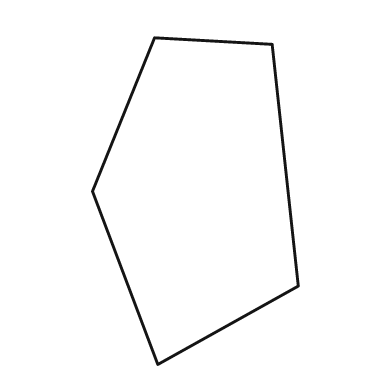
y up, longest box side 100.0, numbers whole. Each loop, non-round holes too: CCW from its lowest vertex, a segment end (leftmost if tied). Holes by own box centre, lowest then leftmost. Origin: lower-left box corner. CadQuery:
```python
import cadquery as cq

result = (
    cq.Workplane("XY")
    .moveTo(20.0, 0.0)
    .lineTo(63.0, 24.0)
    .lineTo(55.0, 98.0)
    .lineTo(19.0, 100.0)
    .lineTo(0.0, 53.0)
    .close()
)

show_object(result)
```